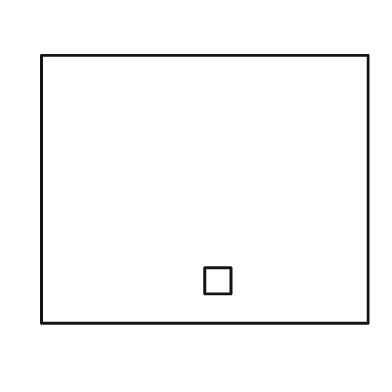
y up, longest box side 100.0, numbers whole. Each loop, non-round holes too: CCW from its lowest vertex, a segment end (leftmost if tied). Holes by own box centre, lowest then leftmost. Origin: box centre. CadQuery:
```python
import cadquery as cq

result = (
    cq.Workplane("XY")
    .moveTo(-50.0, -41.0)
    .lineTo(50.0, -41.0)
    .lineTo(50.0, 41.0)
    .lineTo(-50.0, 41.0)
    .close()
    .moveTo(0.0, -32.0)
    .lineTo(8.0, -32.0)
    .lineTo(8.0, -24.0)
    .lineTo(0.0, -24.0)
    .close()
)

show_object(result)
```